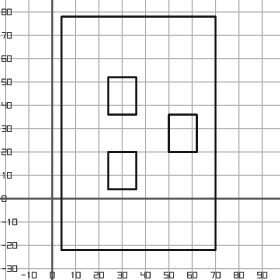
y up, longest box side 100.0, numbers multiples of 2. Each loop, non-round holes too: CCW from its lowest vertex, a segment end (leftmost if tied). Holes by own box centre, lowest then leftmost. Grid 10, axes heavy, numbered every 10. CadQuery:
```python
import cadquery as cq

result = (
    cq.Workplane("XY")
    .moveTo(4.0, -22.0)
    .lineTo(70.0, -22.0)
    .lineTo(70.0, 78.0)
    .lineTo(4.0, 78.0)
    .close()
    .moveTo(24.0, 4.0)
    .lineTo(36.0, 4.0)
    .lineTo(36.0, 20.0)
    .lineTo(24.0, 20.0)
    .close()
    .moveTo(50.0, 20.0)
    .lineTo(62.0, 20.0)
    .lineTo(62.0, 36.0)
    .lineTo(50.0, 36.0)
    .close()
    .moveTo(24.0, 36.0)
    .lineTo(36.0, 36.0)
    .lineTo(36.0, 52.0)
    .lineTo(24.0, 52.0)
    .close()
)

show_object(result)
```